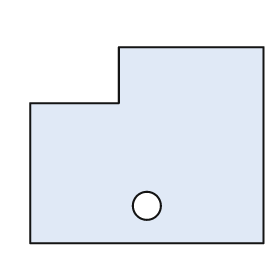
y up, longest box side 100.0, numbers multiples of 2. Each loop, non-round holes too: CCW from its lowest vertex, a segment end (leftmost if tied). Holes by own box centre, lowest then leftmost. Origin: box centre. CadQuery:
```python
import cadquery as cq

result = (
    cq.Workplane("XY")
    .moveTo(-50.0, -42.0)
    .lineTo(50.0, -42.0)
    .lineTo(50.0, 42.0)
    .lineTo(-12.0, 42.0)
    .lineTo(-12.0, 18.0)
    .lineTo(-50.0, 18.0)
    .close()
    .moveTo(0.0, -26.0)
    .circle(6.0)
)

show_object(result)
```